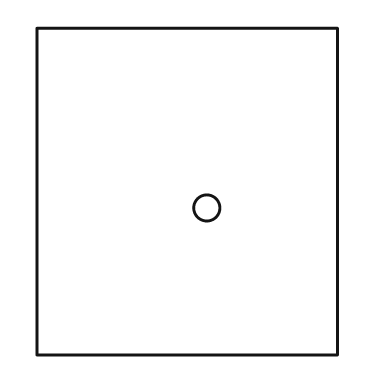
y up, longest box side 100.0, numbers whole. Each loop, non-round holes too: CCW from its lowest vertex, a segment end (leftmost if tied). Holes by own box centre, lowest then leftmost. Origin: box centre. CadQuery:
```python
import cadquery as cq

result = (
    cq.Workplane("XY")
    .moveTo(-46.0, -50.0)
    .lineTo(46.0, -50.0)
    .lineTo(46.0, 50.0)
    .lineTo(-46.0, 50.0)
    .close()
    .moveTo(6.0, -5.0)
    .circle(4.0)
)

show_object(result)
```